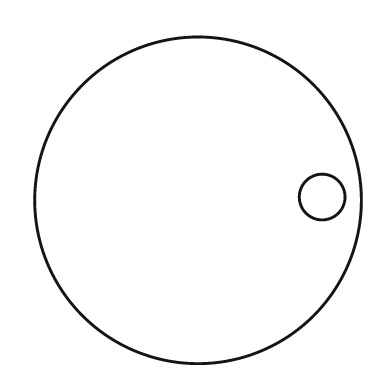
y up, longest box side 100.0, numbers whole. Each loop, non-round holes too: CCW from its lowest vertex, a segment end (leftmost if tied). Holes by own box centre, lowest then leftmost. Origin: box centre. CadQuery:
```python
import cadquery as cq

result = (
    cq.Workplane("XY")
    .moveTo(0.0, 0.0)
    .circle(50.0)
    .moveTo(38.0, 1.0)
    .circle(7.0)
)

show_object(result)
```